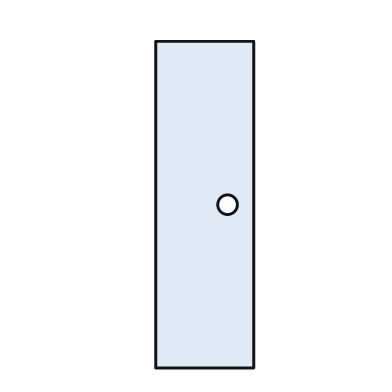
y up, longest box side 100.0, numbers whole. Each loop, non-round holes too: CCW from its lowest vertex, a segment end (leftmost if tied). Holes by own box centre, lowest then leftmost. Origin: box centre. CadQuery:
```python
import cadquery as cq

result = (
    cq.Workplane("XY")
    .moveTo(-15.0, -50.0)
    .lineTo(15.0, -50.0)
    .lineTo(15.0, 50.0)
    .lineTo(-15.0, 50.0)
    .close()
    .moveTo(7.0, 0.0)
    .circle(3.0)
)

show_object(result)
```